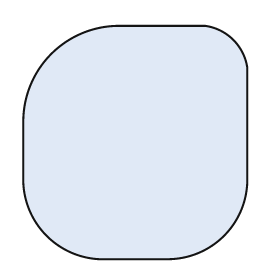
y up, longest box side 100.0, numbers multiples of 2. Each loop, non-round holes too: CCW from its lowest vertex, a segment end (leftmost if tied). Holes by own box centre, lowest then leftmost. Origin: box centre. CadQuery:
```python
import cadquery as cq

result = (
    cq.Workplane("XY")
    .moveTo(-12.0, -50.0)
    .lineTo(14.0, -50.0)
    .threePointArc((38.0, -40.0), (48.0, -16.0))
    .lineTo(48.0, 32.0)
    .threePointArc((42.0, 44.0), (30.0, 50.0))
    .lineTo(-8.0, 50.0)
    .threePointArc((-36.0, 38.0), (-48.0, 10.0))
    .lineTo(-48.0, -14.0)
    .threePointArc((-38.0, -40.0), (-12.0, -50.0))
    .close()
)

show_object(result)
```